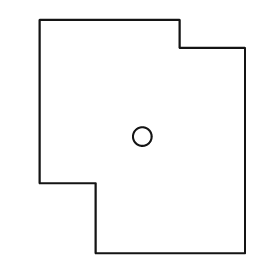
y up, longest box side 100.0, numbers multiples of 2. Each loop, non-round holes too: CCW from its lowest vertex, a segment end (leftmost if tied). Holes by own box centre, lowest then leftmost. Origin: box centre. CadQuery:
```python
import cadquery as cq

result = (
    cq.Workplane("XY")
    .moveTo(-20.0, -50.0)
    .lineTo(44.0, -50.0)
    .lineTo(44.0, 38.0)
    .lineTo(16.0, 38.0)
    .lineTo(16.0, 50.0)
    .lineTo(-44.0, 50.0)
    .lineTo(-44.0, -20.0)
    .lineTo(-20.0, -20.0)
    .close()
    .moveTo(0.0, 0.0)
    .circle(4.0)
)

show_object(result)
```